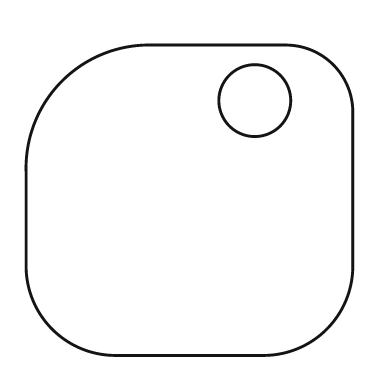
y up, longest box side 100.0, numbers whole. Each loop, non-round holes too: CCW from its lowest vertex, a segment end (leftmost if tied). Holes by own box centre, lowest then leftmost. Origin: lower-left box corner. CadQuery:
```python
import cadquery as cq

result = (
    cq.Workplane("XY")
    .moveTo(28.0, 0.0)
    .lineTo(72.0, 0.0)
    .threePointArc((92.0, 8.0), (100.0, 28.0))
    .lineTo(100.0, 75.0)
    .threePointArc((94.0, 89.0), (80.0, 95.0))
    .lineTo(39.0, 95.0)
    .threePointArc((11.0, 84.0), (0.0, 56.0))
    .lineTo(0.0, 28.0)
    .threePointArc((8.0, 8.0), (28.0, 0.0))
    .close()
    .moveTo(70.0, 78.0)
    .circle(11.0)
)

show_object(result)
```